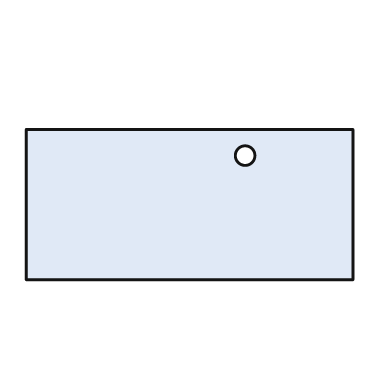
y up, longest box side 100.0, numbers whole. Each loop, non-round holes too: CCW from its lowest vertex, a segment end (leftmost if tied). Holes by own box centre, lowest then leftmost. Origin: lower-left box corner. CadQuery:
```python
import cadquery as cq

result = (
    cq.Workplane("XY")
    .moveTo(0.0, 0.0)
    .lineTo(100.0, 0.0)
    .lineTo(100.0, 46.0)
    .lineTo(0.0, 46.0)
    .close()
    .moveTo(67.0, 38.0)
    .circle(3.0)
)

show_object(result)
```